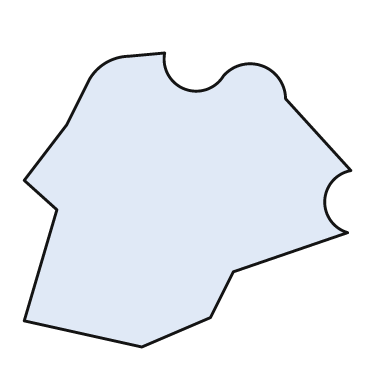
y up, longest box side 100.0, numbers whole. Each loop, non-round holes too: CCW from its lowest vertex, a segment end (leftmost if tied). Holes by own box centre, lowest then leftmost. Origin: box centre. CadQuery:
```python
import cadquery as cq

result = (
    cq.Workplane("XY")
    .moveTo(-14.0, -45.0)
    .lineTo(7.0, -36.0)
    .lineTo(14.0, -22.0)
    .lineTo(49.0, -10.0)
    .threePointArc((42.0, 0.0), (50.0, 9.0))
    .lineTo(30.0, 31.0)
    .threePointArc((23.0, 41.0), (11.0, 38.0))
    .threePointArc((-1.0, 34.0), (-7.0, 45.0))
    .lineTo(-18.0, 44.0)
    .threePointArc((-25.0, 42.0), (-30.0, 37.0))
    .lineTo(-37.0, 23.0)
    .lineTo(-50.0, 6.0)
    .lineTo(-40.0, -3.0)
    .lineTo(-50.0, -37.0)
    .close()
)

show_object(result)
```